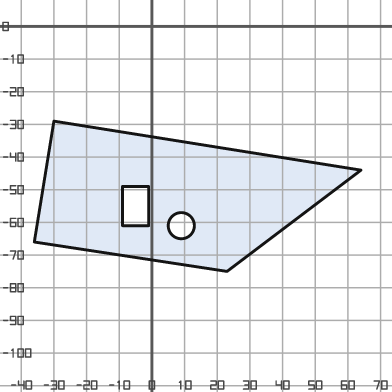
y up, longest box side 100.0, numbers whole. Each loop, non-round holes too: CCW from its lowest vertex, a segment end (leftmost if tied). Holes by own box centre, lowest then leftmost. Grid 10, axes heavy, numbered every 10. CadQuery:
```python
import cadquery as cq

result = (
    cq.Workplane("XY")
    .moveTo(23.0, -75.0)
    .lineTo(64.0, -44.0)
    .lineTo(-30.0, -29.0)
    .lineTo(-36.0, -66.0)
    .close()
    .moveTo(9.0, -61.0)
    .circle(4.0)
    .moveTo(-9.0, -61.0)
    .lineTo(-1.0, -61.0)
    .lineTo(-1.0, -49.0)
    .lineTo(-9.0, -49.0)
    .close()
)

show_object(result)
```